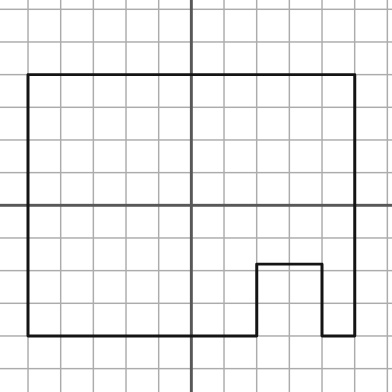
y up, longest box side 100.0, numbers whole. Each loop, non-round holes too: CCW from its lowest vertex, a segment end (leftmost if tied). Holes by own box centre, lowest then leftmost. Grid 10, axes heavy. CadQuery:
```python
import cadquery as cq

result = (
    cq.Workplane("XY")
    .moveTo(-50.0, -40.0)
    .lineTo(20.0, -40.0)
    .lineTo(20.0, -18.0)
    .lineTo(40.0, -18.0)
    .lineTo(40.0, -40.0)
    .lineTo(50.0, -40.0)
    .lineTo(50.0, 40.0)
    .lineTo(-50.0, 40.0)
    .close()
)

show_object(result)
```